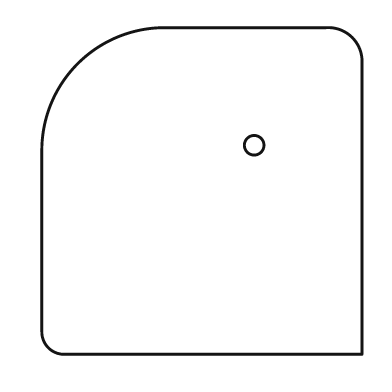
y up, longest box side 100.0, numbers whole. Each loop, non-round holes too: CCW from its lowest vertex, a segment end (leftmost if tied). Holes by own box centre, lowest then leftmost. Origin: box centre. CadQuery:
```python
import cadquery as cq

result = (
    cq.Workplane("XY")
    .moveTo(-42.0, -50.0)
    .lineTo(49.0, -50.0)
    .lineTo(49.0, 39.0)
    .threePointArc((46.0, 47.0), (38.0, 50.0))
    .lineTo(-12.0, 50.0)
    .threePointArc((-38.0, 39.0), (-49.0, 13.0))
    .lineTo(-49.0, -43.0)
    .threePointArc((-47.0, -48.0), (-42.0, -50.0))
    .close()
    .moveTo(16.0, 14.0)
    .circle(3.0)
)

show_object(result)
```